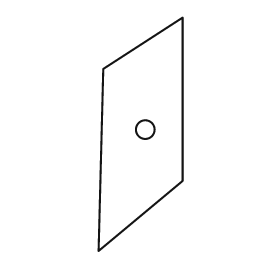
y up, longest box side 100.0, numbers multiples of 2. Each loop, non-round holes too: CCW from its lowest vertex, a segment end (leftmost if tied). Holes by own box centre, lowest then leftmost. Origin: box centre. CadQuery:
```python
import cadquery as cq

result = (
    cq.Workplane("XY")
    .moveTo(-18.0, -50.0)
    .lineTo(18.0, -20.0)
    .lineTo(18.0, 50.0)
    .lineTo(-16.0, 28.0)
    .close()
    .moveTo(2.0, 2.0)
    .circle(4.0)
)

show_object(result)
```